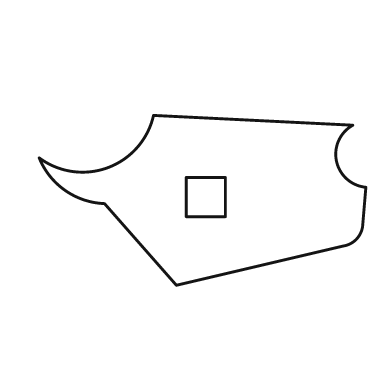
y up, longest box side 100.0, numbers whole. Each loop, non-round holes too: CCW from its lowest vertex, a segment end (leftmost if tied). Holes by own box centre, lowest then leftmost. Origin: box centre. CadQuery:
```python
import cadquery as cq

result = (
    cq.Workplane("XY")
    .moveTo(-8.0, -26.0)
    .lineTo(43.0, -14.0)
    .threePointArc((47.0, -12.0), (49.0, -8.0))
    .lineTo(50.0, 4.0)
    .threePointArc((41.0, 12.0), (46.0, 23.0))
    .lineTo(-15.0, 26.0)
    .threePointArc((-29.0, 10.0), (-50.0, 13.0))
    .threePointArc((-42.0, 3.0), (-30.0, -1.0))
    .close()
    .moveTo(-5.0, -5.0)
    .lineTo(7.0, -5.0)
    .lineTo(7.0, 7.0)
    .lineTo(-5.0, 7.0)
    .close()
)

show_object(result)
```